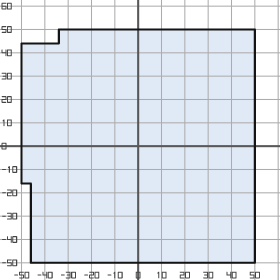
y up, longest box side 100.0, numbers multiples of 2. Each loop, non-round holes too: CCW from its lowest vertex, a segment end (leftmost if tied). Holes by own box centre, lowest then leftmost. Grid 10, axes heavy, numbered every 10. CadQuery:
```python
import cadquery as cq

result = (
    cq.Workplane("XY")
    .moveTo(-46.0, -50.0)
    .lineTo(50.0, -50.0)
    .lineTo(50.0, 50.0)
    .lineTo(-34.0, 50.0)
    .lineTo(-34.0, 44.0)
    .lineTo(-50.0, 44.0)
    .lineTo(-50.0, -16.0)
    .lineTo(-46.0, -16.0)
    .close()
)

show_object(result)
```